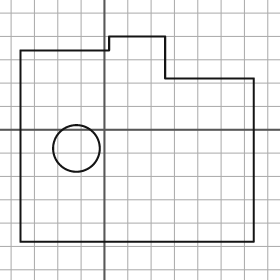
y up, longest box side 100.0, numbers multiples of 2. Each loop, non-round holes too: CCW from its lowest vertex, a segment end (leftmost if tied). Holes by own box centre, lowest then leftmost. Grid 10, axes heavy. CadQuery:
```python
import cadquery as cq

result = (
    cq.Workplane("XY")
    .moveTo(-36.0, -48.0)
    .lineTo(64.0, -48.0)
    .lineTo(64.0, 22.0)
    .lineTo(26.0, 22.0)
    .lineTo(26.0, 40.0)
    .lineTo(2.0, 40.0)
    .lineTo(2.0, 34.0)
    .lineTo(-36.0, 34.0)
    .close()
    .moveTo(-12.0, -8.0)
    .circle(10.0)
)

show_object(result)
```